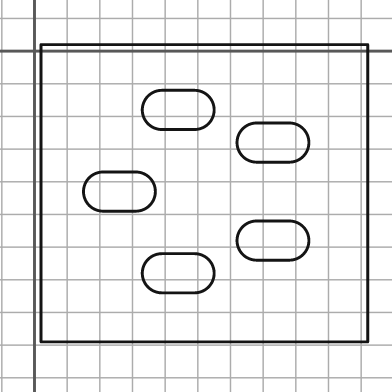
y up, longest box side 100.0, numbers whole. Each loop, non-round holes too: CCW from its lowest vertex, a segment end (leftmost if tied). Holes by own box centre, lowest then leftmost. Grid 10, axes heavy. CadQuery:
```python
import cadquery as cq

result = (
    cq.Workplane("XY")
    .moveTo(2.0, -89.0)
    .lineTo(102.0, -89.0)
    .lineTo(102.0, 2.0)
    .lineTo(2.0, 2.0)
    .close()
    .moveTo(39.0, -74.0)
    .lineTo(49.0, -74.0)
    .threePointArc((55.0, -68.0), (49.0, -62.0))
    .lineTo(39.0, -62.0)
    .threePointArc((33.0, -68.0), (39.0, -74.0))
    .close()
    .moveTo(68.0, -64.0)
    .lineTo(78.0, -64.0)
    .threePointArc((84.0, -58.0), (78.0, -52.0))
    .lineTo(68.0, -52.0)
    .threePointArc((62.0, -58.0), (68.0, -64.0))
    .close()
    .moveTo(21.0, -49.0)
    .lineTo(31.0, -49.0)
    .threePointArc((37.0, -43.0), (31.0, -37.0))
    .lineTo(21.0, -37.0)
    .threePointArc((15.0, -43.0), (21.0, -49.0))
    .close()
    .moveTo(68.0, -34.0)
    .lineTo(78.0, -34.0)
    .threePointArc((84.0, -28.0), (78.0, -22.0))
    .lineTo(68.0, -22.0)
    .threePointArc((62.0, -28.0), (68.0, -34.0))
    .close()
    .moveTo(39.0, -24.0)
    .lineTo(49.0, -24.0)
    .threePointArc((55.0, -18.0), (49.0, -12.0))
    .lineTo(39.0, -12.0)
    .threePointArc((33.0, -18.0), (39.0, -24.0))
    .close()
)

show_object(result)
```